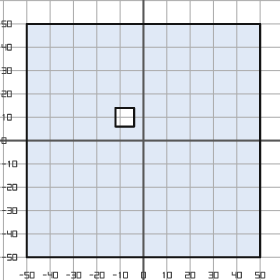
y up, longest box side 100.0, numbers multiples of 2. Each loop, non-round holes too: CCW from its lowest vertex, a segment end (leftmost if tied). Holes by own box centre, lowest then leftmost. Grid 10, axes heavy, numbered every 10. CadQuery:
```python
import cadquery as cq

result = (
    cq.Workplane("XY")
    .moveTo(-50.0, -50.0)
    .lineTo(50.0, -50.0)
    .lineTo(50.0, 50.0)
    .lineTo(-50.0, 50.0)
    .close()
    .moveTo(-12.0, 6.0)
    .lineTo(-4.0, 6.0)
    .lineTo(-4.0, 14.0)
    .lineTo(-12.0, 14.0)
    .close()
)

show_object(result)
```